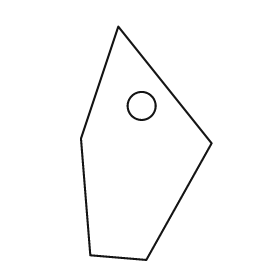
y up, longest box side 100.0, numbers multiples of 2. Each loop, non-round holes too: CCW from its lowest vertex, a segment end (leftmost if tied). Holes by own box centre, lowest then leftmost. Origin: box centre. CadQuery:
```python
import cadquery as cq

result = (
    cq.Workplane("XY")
    .moveTo(0.0, -50.0)
    .lineTo(28.0, 0.0)
    .lineTo(-12.0, 50.0)
    .lineTo(-28.0, 2.0)
    .lineTo(-24.0, -48.0)
    .close()
    .moveTo(-2.0, 16.0)
    .circle(6.0)
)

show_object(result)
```